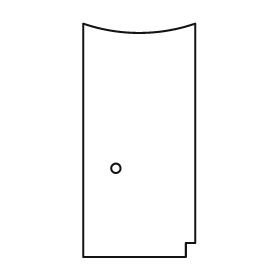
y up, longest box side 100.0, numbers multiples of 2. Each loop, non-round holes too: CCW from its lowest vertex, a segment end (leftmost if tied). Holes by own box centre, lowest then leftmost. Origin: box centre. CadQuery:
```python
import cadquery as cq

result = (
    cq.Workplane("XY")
    .moveTo(-24.0, -50.0)
    .lineTo(20.0, -50.0)
    .lineTo(20.0, -44.0)
    .lineTo(24.0, -44.0)
    .lineTo(24.0, 50.0)
    .threePointArc((0.0, 46.0), (-24.0, 50.0))
    .close()
    .moveTo(-10.0, -12.0)
    .circle(2.0)
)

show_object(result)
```